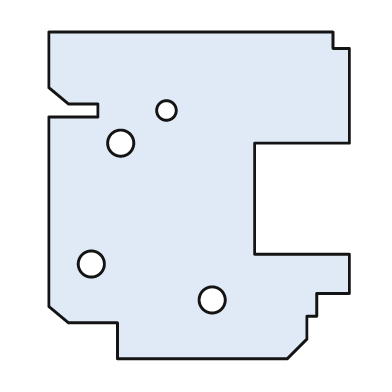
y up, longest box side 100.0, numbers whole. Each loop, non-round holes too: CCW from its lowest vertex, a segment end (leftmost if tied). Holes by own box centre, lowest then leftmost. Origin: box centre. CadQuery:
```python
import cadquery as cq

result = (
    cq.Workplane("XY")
    .moveTo(-25.0, -50.0)
    .lineTo(27.0, -50.0)
    .lineTo(33.0, -44.0)
    .lineTo(33.0, -37.0)
    .lineTo(36.0, -37.0)
    .lineTo(36.0, -30.0)
    .lineTo(46.0, -30.0)
    .lineTo(46.0, -18.0)
    .lineTo(17.0, -18.0)
    .lineTo(17.0, 16.0)
    .lineTo(46.0, 16.0)
    .lineTo(46.0, 45.0)
    .lineTo(41.0, 45.0)
    .lineTo(41.0, 50.0)
    .lineTo(-46.0, 50.0)
    .lineTo(-46.0, 33.0)
    .lineTo(-40.0, 28.0)
    .lineTo(-31.0, 28.0)
    .lineTo(-31.0, 24.0)
    .lineTo(-46.0, 24.0)
    .lineTo(-46.0, -34.0)
    .lineTo(-40.0, -39.0)
    .lineTo(-25.0, -39.0)
    .close()
    .moveTo(4.0, -32.0)
    .circle(4.0)
    .moveTo(-33.0, -21.0)
    .circle(4.0)
    .moveTo(-24.0, 16.0)
    .circle(4.0)
    .moveTo(-10.0, 26.0)
    .circle(3.0)
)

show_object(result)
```